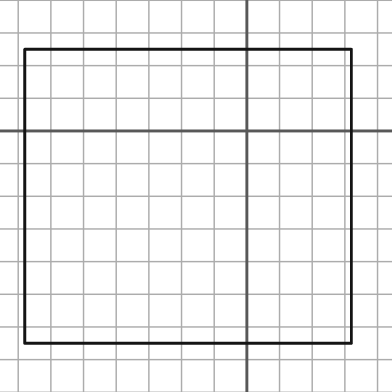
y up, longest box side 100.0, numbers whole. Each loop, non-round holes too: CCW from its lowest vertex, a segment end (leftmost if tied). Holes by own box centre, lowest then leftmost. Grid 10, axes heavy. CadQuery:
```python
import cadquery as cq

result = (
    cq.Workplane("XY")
    .moveTo(-68.0, -65.0)
    .lineTo(32.0, -65.0)
    .lineTo(32.0, 25.0)
    .lineTo(-68.0, 25.0)
    .close()
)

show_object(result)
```